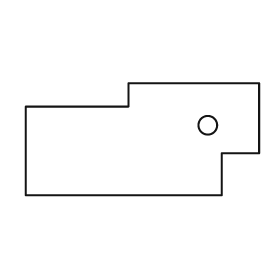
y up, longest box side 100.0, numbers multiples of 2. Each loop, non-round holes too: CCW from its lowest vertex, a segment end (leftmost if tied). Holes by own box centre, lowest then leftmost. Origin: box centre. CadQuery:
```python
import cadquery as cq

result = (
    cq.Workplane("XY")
    .moveTo(-50.0, -24.0)
    .lineTo(34.0, -24.0)
    .lineTo(34.0, -6.0)
    .lineTo(50.0, -6.0)
    .lineTo(50.0, 24.0)
    .lineTo(-6.0, 24.0)
    .lineTo(-6.0, 14.0)
    .lineTo(-50.0, 14.0)
    .close()
    .moveTo(28.0, 6.0)
    .circle(4.0)
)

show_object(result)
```